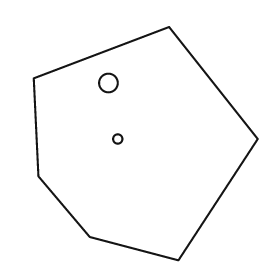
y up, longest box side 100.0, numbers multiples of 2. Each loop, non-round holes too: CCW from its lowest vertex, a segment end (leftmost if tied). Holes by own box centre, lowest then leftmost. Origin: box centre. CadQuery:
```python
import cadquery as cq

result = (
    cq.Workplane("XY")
    .moveTo(14.0, -50.0)
    .lineTo(48.0, 2.0)
    .lineTo(10.0, 50.0)
    .lineTo(-48.0, 28.0)
    .lineTo(-46.0, -14.0)
    .lineTo(-24.0, -40.0)
    .close()
    .moveTo(-12.0, 2.0)
    .circle(2.0)
    .moveTo(-16.0, 26.0)
    .circle(4.0)
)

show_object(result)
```